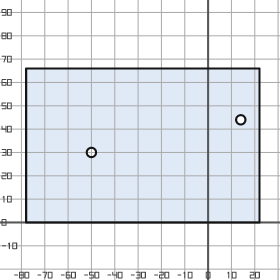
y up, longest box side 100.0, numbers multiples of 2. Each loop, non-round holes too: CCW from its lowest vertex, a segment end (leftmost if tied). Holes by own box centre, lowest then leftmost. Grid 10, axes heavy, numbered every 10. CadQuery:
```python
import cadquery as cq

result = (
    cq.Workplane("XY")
    .moveTo(-78.0, 0.0)
    .lineTo(22.0, 0.0)
    .lineTo(22.0, 66.0)
    .lineTo(-78.0, 66.0)
    .close()
    .moveTo(-50.0, 30.0)
    .circle(2.0)
    .moveTo(14.0, 44.0)
    .circle(2.0)
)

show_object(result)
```